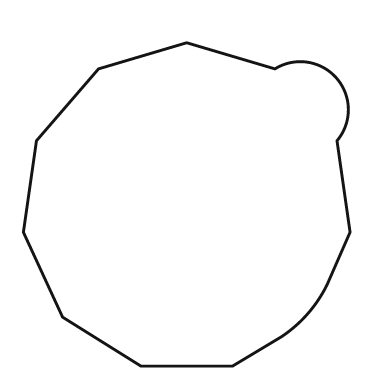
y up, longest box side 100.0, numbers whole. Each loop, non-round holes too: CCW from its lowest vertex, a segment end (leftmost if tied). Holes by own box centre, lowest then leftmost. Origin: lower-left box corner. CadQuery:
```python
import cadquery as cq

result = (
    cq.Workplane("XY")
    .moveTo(36.0, 0.0)
    .lineTo(64.0, 0.0)
    .lineTo(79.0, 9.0)
    .threePointArc((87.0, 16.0), (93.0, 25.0))
    .lineTo(100.0, 41.0)
    .lineTo(96.0, 69.0)
    .threePointArc((96.0, 88.0), (77.0, 91.0))
    .lineTo(50.0, 99.0)
    .lineTo(23.0, 91.0)
    .lineTo(4.0, 69.0)
    .lineTo(0.0, 41.0)
    .lineTo(12.0, 15.0)
    .close()
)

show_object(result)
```